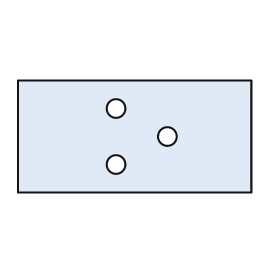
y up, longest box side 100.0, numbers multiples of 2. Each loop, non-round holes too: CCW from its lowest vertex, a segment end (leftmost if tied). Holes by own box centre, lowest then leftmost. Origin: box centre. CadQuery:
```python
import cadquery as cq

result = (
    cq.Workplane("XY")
    .moveTo(-50.0, -24.0)
    .lineTo(50.0, -24.0)
    .lineTo(50.0, 24.0)
    .lineTo(-50.0, 24.0)
    .close()
    .moveTo(-8.0, -12.0)
    .circle(4.0)
    .moveTo(14.0, 0.0)
    .circle(4.0)
    .moveTo(-8.0, 12.0)
    .circle(4.0)
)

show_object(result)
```